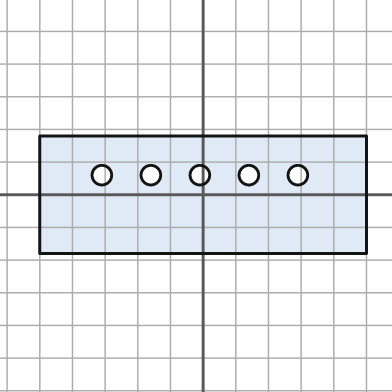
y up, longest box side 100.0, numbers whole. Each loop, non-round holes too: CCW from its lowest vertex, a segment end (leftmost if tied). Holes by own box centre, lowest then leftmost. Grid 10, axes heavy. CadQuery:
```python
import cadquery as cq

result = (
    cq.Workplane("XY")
    .moveTo(-50.0, -18.0)
    .lineTo(50.0, -18.0)
    .lineTo(50.0, 18.0)
    .lineTo(-50.0, 18.0)
    .close()
    .moveTo(-31.0, 6.0)
    .circle(3.0)
    .moveTo(-16.0, 6.0)
    .circle(3.0)
    .moveTo(-1.0, 6.0)
    .circle(3.0)
    .moveTo(14.0, 6.0)
    .circle(3.0)
    .moveTo(29.0, 6.0)
    .circle(3.0)
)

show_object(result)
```